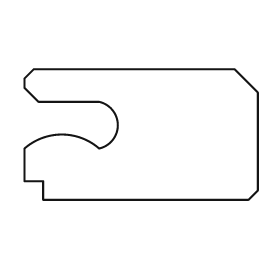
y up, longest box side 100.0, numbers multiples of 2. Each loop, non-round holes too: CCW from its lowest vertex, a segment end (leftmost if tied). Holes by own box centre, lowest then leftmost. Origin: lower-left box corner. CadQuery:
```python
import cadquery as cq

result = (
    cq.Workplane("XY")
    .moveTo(8.0, 0.0)
    .lineTo(96.0, 0.0)
    .lineTo(100.0, 4.0)
    .lineTo(100.0, 46.0)
    .lineTo(90.0, 56.0)
    .lineTo(4.0, 56.0)
    .lineTo(0.0, 52.0)
    .lineTo(0.0, 48.0)
    .lineTo(6.0, 42.0)
    .lineTo(32.0, 42.0)
    .threePointArc((40.0, 32.0), (32.0, 22.0))
    .threePointArc((16.0, 28.0), (0.0, 22.0))
    .lineTo(0.0, 8.0)
    .lineTo(8.0, 8.0)
    .close()
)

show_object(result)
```